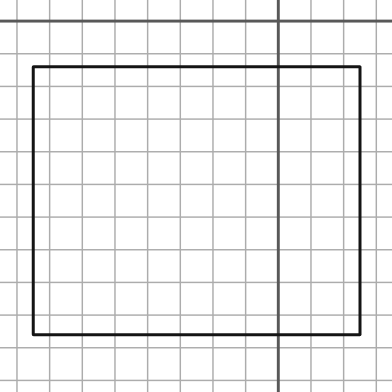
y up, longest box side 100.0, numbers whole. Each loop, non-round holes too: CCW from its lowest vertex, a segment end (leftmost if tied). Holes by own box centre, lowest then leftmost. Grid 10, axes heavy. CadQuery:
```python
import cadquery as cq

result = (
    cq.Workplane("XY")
    .moveTo(-75.0, -96.0)
    .lineTo(25.0, -96.0)
    .lineTo(25.0, -14.0)
    .lineTo(-75.0, -14.0)
    .close()
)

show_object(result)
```